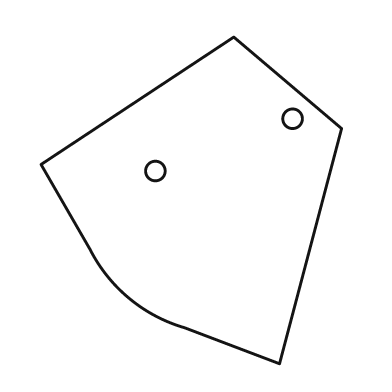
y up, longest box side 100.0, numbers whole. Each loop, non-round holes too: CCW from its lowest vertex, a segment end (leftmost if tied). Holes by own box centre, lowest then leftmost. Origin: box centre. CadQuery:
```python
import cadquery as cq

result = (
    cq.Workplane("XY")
    .moveTo(27.0, -50.0)
    .lineTo(46.0, 22.0)
    .lineTo(13.0, 50.0)
    .lineTo(-46.0, 11.0)
    .lineTo(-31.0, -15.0)
    .threePointArc((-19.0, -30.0), (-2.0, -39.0))
    .close()
    .moveTo(-11.0, 9.0)
    .circle(3.0)
    .moveTo(31.0, 25.0)
    .circle(3.0)
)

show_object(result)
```